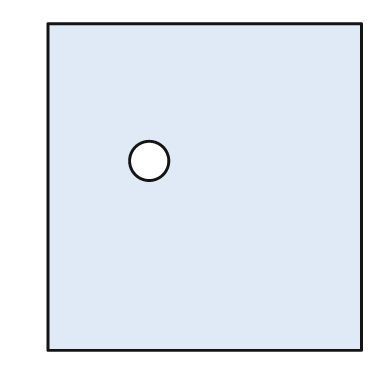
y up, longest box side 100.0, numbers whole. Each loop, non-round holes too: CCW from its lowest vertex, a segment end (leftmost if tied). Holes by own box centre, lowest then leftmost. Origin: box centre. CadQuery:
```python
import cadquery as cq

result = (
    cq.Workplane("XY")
    .moveTo(-48.0, -50.0)
    .lineTo(48.0, -50.0)
    .lineTo(48.0, 50.0)
    .lineTo(-48.0, 50.0)
    .close()
    .moveTo(-17.0, 8.0)
    .circle(6.0)
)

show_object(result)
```